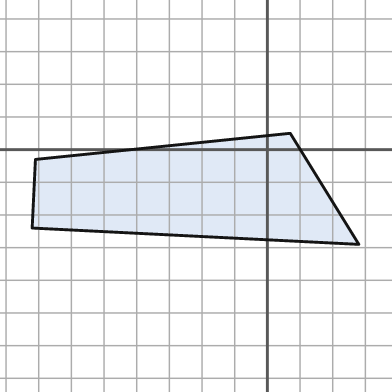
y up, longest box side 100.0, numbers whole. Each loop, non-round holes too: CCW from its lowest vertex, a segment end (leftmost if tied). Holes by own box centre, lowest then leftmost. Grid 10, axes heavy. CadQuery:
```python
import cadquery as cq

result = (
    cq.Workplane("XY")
    .moveTo(28.0, -29.0)
    .lineTo(7.0, 5.0)
    .lineTo(-71.0, -3.0)
    .lineTo(-72.0, -24.0)
    .close()
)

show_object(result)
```